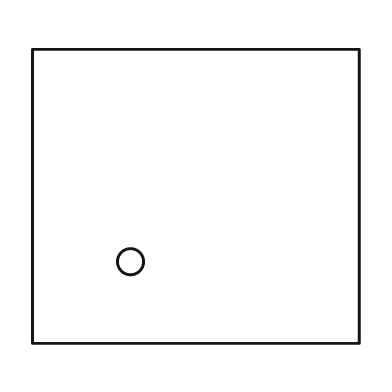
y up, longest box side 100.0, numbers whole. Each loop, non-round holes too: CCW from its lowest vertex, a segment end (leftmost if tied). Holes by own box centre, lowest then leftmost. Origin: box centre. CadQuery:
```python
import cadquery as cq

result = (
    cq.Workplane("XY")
    .moveTo(-50.0, -45.0)
    .lineTo(50.0, -45.0)
    .lineTo(50.0, 45.0)
    .lineTo(-50.0, 45.0)
    .close()
    .moveTo(-20.0, -20.0)
    .circle(4.0)
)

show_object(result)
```